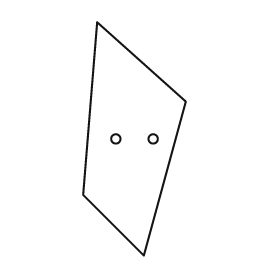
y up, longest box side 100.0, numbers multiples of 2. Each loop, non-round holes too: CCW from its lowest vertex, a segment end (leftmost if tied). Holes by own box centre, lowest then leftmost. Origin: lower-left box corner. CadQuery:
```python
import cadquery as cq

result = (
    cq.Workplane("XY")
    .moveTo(26.0, 0.0)
    .lineTo(44.0, 66.0)
    .lineTo(6.0, 100.0)
    .lineTo(0.0, 26.0)
    .close()
    .moveTo(14.0, 50.0)
    .circle(2.0)
    .moveTo(30.0, 50.0)
    .circle(2.0)
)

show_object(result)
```